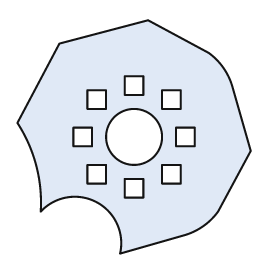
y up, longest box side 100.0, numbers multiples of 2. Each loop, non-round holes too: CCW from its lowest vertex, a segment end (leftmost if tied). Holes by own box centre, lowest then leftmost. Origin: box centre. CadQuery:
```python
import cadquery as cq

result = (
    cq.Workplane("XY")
    .moveTo(-6.0, -50.0)
    .lineTo(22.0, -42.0)
    .threePointArc((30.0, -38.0), (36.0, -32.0))
    .lineTo(50.0, -6.0)
    .lineTo(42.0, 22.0)
    .threePointArc((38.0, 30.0), (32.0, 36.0))
    .lineTo(6.0, 50.0)
    .lineTo(-32.0, 40.0)
    .lineTo(-50.0, 6.0)
    .threePointArc((-42.0, -12.0), (-40.0, -32.0))
    .threePointArc((-16.0, -28.0), (-6.0, -50.0))
    .close()
    .moveTo(-4.0, -26.0)
    .lineTo(4.0, -26.0)
    .lineTo(4.0, -18.0)
    .lineTo(-4.0, -18.0)
    .close()
    .moveTo(-20.0, -20.0)
    .lineTo(-12.0, -20.0)
    .lineTo(-12.0, -12.0)
    .lineTo(-20.0, -12.0)
    .close()
    .moveTo(12.0, -20.0)
    .lineTo(20.0, -20.0)
    .lineTo(20.0, -12.0)
    .lineTo(12.0, -12.0)
    .close()
    .moveTo(-26.0, -4.0)
    .lineTo(-18.0, -4.0)
    .lineTo(-18.0, 4.0)
    .lineTo(-26.0, 4.0)
    .close()
    .moveTo(0.0, 0.0)
    .circle(12.0)
    .moveTo(18.0, -4.0)
    .lineTo(26.0, -4.0)
    .lineTo(26.0, 4.0)
    .lineTo(18.0, 4.0)
    .close()
    .moveTo(-20.0, 12.0)
    .lineTo(-12.0, 12.0)
    .lineTo(-12.0, 20.0)
    .lineTo(-20.0, 20.0)
    .close()
    .moveTo(12.0, 12.0)
    .lineTo(20.0, 12.0)
    .lineTo(20.0, 20.0)
    .lineTo(12.0, 20.0)
    .close()
    .moveTo(-4.0, 18.0)
    .lineTo(4.0, 18.0)
    .lineTo(4.0, 26.0)
    .lineTo(-4.0, 26.0)
    .close()
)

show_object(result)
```